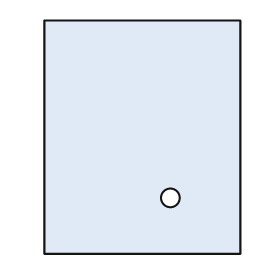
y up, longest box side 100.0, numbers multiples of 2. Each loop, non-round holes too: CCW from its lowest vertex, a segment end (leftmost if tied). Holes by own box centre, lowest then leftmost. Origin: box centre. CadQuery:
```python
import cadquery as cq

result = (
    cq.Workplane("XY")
    .moveTo(-42.0, -50.0)
    .lineTo(42.0, -50.0)
    .lineTo(42.0, 50.0)
    .lineTo(-42.0, 50.0)
    .close()
    .moveTo(12.0, -26.0)
    .circle(4.0)
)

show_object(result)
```